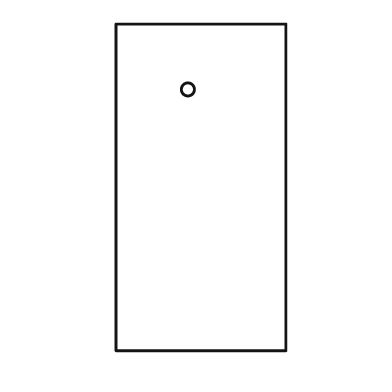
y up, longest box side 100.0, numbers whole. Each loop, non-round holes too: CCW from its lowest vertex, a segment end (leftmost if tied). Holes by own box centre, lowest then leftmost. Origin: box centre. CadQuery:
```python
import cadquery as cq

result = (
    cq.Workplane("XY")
    .moveTo(-26.0, -50.0)
    .lineTo(26.0, -50.0)
    .lineTo(26.0, 50.0)
    .lineTo(-26.0, 50.0)
    .close()
    .moveTo(-4.0, 30.0)
    .circle(2.0)
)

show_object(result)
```